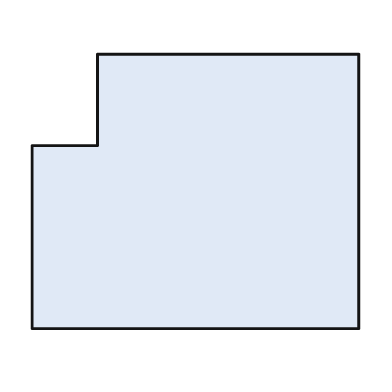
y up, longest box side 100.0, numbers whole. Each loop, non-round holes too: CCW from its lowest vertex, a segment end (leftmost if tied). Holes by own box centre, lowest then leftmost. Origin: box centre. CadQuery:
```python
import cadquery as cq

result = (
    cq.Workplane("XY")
    .moveTo(-50.0, -42.0)
    .lineTo(50.0, -42.0)
    .lineTo(50.0, 42.0)
    .lineTo(-30.0, 42.0)
    .lineTo(-30.0, 14.0)
    .lineTo(-50.0, 14.0)
    .close()
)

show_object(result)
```